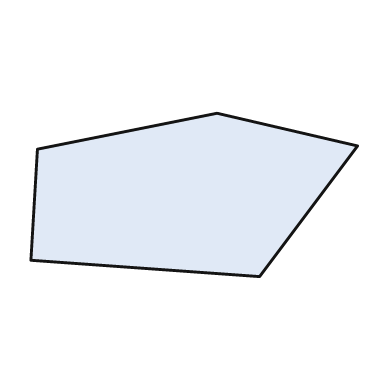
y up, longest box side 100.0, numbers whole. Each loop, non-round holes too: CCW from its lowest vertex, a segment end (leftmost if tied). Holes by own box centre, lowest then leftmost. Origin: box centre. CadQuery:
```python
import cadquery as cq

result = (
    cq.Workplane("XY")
    .moveTo(20.0, -25.0)
    .lineTo(50.0, 15.0)
    .lineTo(7.0, 25.0)
    .lineTo(-48.0, 14.0)
    .lineTo(-50.0, -20.0)
    .close()
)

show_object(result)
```